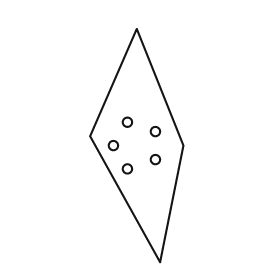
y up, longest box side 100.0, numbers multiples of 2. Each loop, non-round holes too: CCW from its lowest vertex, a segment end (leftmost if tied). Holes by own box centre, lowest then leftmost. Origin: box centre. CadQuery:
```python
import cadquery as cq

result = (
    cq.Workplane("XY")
    .moveTo(10.0, -50.0)
    .lineTo(20.0, 0.0)
    .lineTo(0.0, 50.0)
    .lineTo(-20.0, 4.0)
    .close()
    .moveTo(-4.0, -10.0)
    .circle(2.0)
    .moveTo(8.0, -6.0)
    .circle(2.0)
    .moveTo(-10.0, 0.0)
    .circle(2.0)
    .moveTo(8.0, 6.0)
    .circle(2.0)
    .moveTo(-4.0, 10.0)
    .circle(2.0)
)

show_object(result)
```